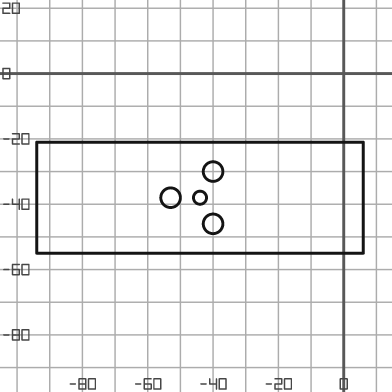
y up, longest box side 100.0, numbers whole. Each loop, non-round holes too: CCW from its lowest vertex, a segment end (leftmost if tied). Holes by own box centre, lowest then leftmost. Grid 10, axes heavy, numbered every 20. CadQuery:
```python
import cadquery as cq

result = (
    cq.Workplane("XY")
    .moveTo(-94.0, -55.0)
    .lineTo(6.0, -55.0)
    .lineTo(6.0, -21.0)
    .lineTo(-94.0, -21.0)
    .close()
    .moveTo(-40.0, -46.0)
    .circle(3.0)
    .moveTo(-53.0, -38.0)
    .circle(3.0)
    .moveTo(-44.0, -38.0)
    .circle(2.0)
    .moveTo(-40.0, -30.0)
    .circle(3.0)
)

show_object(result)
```